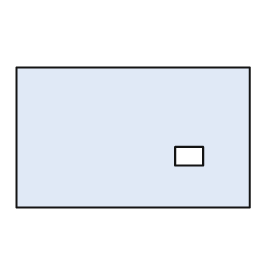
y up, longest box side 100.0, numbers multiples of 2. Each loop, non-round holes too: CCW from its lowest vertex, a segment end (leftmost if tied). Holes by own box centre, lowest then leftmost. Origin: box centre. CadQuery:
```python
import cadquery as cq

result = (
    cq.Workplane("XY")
    .moveTo(-50.0, -30.0)
    .lineTo(50.0, -30.0)
    .lineTo(50.0, 30.0)
    .lineTo(-50.0, 30.0)
    .close()
    .moveTo(18.0, -12.0)
    .lineTo(30.0, -12.0)
    .lineTo(30.0, -4.0)
    .lineTo(18.0, -4.0)
    .close()
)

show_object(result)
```